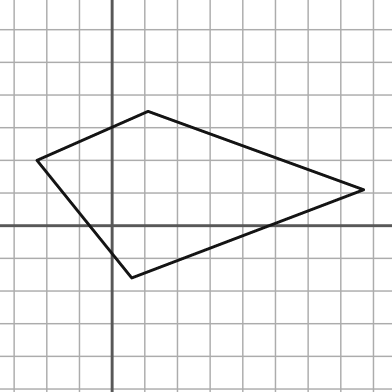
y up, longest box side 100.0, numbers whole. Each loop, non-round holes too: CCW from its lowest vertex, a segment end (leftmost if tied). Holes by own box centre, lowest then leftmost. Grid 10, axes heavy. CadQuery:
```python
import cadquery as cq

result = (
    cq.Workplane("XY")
    .moveTo(6.0, -16.0)
    .lineTo(77.0, 11.0)
    .lineTo(11.0, 35.0)
    .lineTo(-23.0, 20.0)
    .close()
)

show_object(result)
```